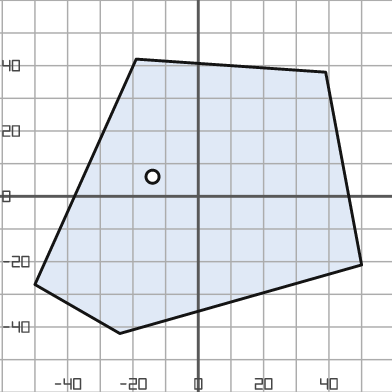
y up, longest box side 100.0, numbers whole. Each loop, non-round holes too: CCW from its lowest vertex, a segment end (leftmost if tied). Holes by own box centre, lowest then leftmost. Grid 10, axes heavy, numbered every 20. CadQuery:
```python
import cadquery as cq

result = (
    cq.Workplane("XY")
    .moveTo(-24.0, -42.0)
    .lineTo(50.0, -21.0)
    .lineTo(39.0, 38.0)
    .lineTo(-19.0, 42.0)
    .lineTo(-50.0, -27.0)
    .close()
    .moveTo(-14.0, 6.0)
    .circle(2.0)
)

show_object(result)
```